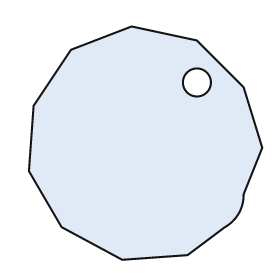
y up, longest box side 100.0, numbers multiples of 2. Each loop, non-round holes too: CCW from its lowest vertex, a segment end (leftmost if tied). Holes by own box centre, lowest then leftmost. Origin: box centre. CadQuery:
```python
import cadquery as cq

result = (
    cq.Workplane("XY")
    .moveTo(-10.0, -50.0)
    .lineTo(18.0, -48.0)
    .lineTo(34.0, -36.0)
    .threePointArc((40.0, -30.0), (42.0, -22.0))
    .lineTo(50.0, -2.0)
    .lineTo(42.0, 24.0)
    .lineTo(22.0, 44.0)
    .lineTo(-6.0, 50.0)
    .lineTo(-32.0, 40.0)
    .lineTo(-48.0, 16.0)
    .lineTo(-50.0, -12.0)
    .lineTo(-36.0, -36.0)
    .close()
    .moveTo(22.0, 26.0)
    .circle(6.0)
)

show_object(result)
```